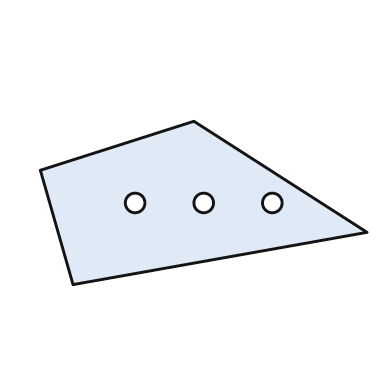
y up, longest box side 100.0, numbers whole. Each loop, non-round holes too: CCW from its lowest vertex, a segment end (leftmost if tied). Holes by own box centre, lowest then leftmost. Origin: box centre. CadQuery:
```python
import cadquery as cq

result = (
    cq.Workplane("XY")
    .moveTo(-40.0, -25.0)
    .lineTo(50.0, -9.0)
    .lineTo(-3.0, 25.0)
    .lineTo(-50.0, 10.0)
    .close()
    .moveTo(-21.0, 0.0)
    .circle(3.0)
    .moveTo(0.0, 0.0)
    .circle(3.0)
    .moveTo(21.0, 0.0)
    .circle(3.0)
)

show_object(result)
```